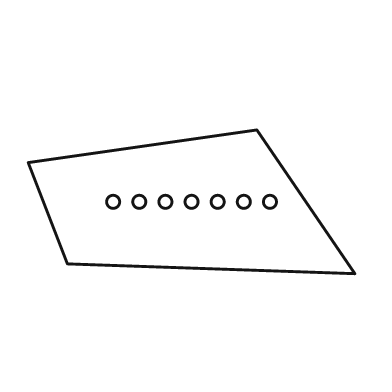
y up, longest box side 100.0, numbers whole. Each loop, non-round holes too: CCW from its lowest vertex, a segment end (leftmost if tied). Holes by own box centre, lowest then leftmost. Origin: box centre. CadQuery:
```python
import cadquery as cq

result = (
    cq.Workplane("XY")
    .moveTo(50.0, -22.0)
    .lineTo(20.0, 22.0)
    .lineTo(-50.0, 12.0)
    .lineTo(-38.0, -19.0)
    .close()
    .moveTo(-24.0, 0.0)
    .circle(2.0)
    .moveTo(-16.0, 0.0)
    .circle(2.0)
    .moveTo(-8.0, 0.0)
    .circle(2.0)
    .moveTo(0.0, 0.0)
    .circle(2.0)
    .moveTo(8.0, 0.0)
    .circle(2.0)
    .moveTo(16.0, 0.0)
    .circle(2.0)
    .moveTo(24.0, 0.0)
    .circle(2.0)
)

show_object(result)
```